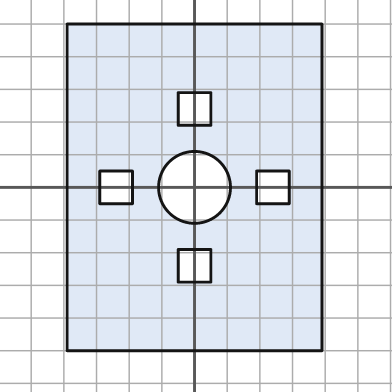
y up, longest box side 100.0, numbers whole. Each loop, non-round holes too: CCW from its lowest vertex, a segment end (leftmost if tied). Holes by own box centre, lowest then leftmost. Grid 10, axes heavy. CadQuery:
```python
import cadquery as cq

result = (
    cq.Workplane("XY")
    .moveTo(-39.0, -50.0)
    .lineTo(39.0, -50.0)
    .lineTo(39.0, 50.0)
    .lineTo(-39.0, 50.0)
    .close()
    .moveTo(-5.0, -29.0)
    .lineTo(5.0, -29.0)
    .lineTo(5.0, -19.0)
    .lineTo(-5.0, -19.0)
    .close()
    .moveTo(-29.0, -5.0)
    .lineTo(-19.0, -5.0)
    .lineTo(-19.0, 5.0)
    .lineTo(-29.0, 5.0)
    .close()
    .moveTo(0.0, 0.0)
    .circle(11.0)
    .moveTo(19.0, -5.0)
    .lineTo(29.0, -5.0)
    .lineTo(29.0, 5.0)
    .lineTo(19.0, 5.0)
    .close()
    .moveTo(-5.0, 19.0)
    .lineTo(5.0, 19.0)
    .lineTo(5.0, 29.0)
    .lineTo(-5.0, 29.0)
    .close()
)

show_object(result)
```